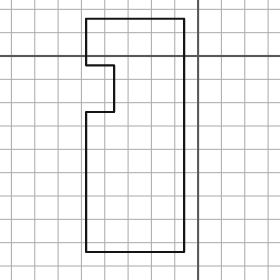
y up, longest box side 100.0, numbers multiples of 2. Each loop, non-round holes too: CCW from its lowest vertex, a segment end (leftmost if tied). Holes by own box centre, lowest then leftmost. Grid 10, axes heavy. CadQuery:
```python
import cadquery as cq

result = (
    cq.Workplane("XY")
    .moveTo(-48.0, -84.0)
    .lineTo(-6.0, -84.0)
    .lineTo(-6.0, 16.0)
    .lineTo(-48.0, 16.0)
    .lineTo(-48.0, -4.0)
    .lineTo(-36.0, -4.0)
    .lineTo(-36.0, -24.0)
    .lineTo(-48.0, -24.0)
    .close()
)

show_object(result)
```